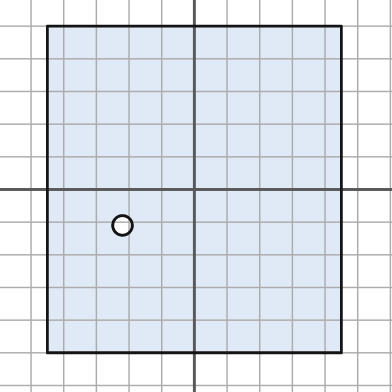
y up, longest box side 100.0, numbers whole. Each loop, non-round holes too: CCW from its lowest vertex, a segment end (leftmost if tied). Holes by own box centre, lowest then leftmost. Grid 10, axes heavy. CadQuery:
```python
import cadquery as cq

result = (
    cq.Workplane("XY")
    .moveTo(-45.0, -50.0)
    .lineTo(45.0, -50.0)
    .lineTo(45.0, 50.0)
    .lineTo(-45.0, 50.0)
    .close()
    .moveTo(-22.0, -11.0)
    .circle(3.0)
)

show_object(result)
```